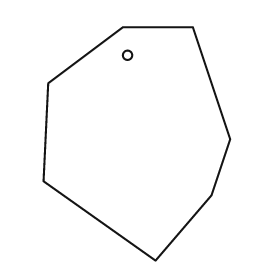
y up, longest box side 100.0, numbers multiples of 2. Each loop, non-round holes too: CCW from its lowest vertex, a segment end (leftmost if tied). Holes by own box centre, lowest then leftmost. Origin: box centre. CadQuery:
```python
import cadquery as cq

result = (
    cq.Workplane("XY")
    .moveTo(8.0, -50.0)
    .lineTo(32.0, -22.0)
    .lineTo(40.0, 2.0)
    .lineTo(24.0, 50.0)
    .lineTo(-6.0, 50.0)
    .lineTo(-38.0, 26.0)
    .lineTo(-40.0, -16.0)
    .close()
    .moveTo(-4.0, 38.0)
    .circle(2.0)
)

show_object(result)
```